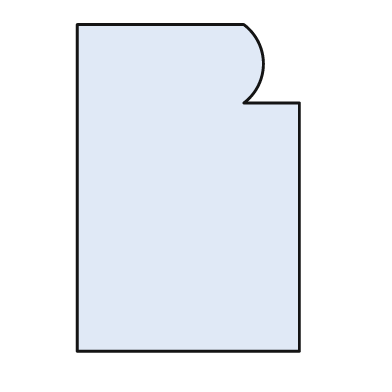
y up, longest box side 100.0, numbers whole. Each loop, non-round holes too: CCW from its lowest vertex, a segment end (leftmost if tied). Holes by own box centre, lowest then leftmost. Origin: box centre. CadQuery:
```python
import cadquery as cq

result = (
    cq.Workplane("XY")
    .moveTo(-34.0, -50.0)
    .lineTo(34.0, -50.0)
    .lineTo(34.0, 26.0)
    .lineTo(17.0, 26.0)
    .threePointArc((23.0, 38.0), (17.0, 50.0))
    .lineTo(-34.0, 50.0)
    .close()
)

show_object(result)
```